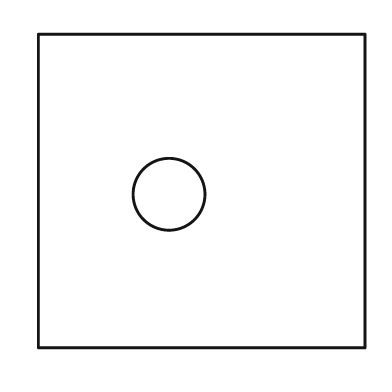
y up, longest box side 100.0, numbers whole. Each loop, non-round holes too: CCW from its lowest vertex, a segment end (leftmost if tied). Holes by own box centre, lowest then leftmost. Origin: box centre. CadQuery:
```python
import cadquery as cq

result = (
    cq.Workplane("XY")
    .moveTo(-50.0, -48.0)
    .lineTo(50.0, -48.0)
    .lineTo(50.0, 48.0)
    .lineTo(-50.0, 48.0)
    .close()
    .moveTo(-10.0, -1.0)
    .circle(11.0)
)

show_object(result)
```